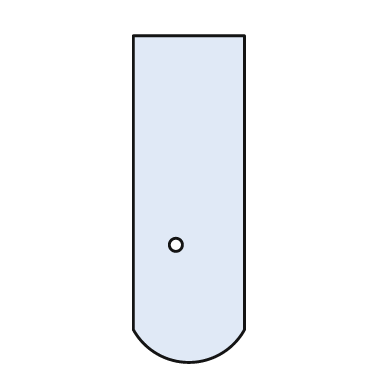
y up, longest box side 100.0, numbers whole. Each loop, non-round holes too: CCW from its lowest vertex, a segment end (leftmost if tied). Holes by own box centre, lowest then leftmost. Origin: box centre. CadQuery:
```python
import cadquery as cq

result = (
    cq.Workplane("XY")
    .moveTo(-17.0, -40.0)
    .threePointArc((0.0, -50.0), (17.0, -40.0))
    .lineTo(17.0, 50.0)
    .lineTo(-17.0, 50.0)
    .close()
    .moveTo(-4.0, -14.0)
    .circle(2.0)
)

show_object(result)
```